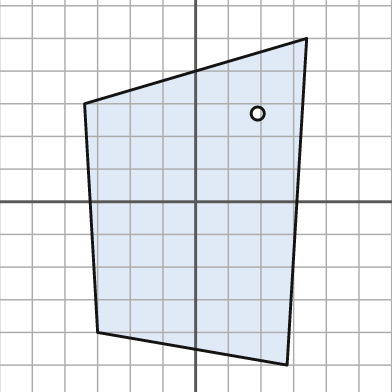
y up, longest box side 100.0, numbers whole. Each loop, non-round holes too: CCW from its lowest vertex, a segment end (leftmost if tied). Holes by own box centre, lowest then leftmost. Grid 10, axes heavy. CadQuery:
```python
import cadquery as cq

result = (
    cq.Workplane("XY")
    .moveTo(28.0, -50.0)
    .lineTo(34.0, 50.0)
    .lineTo(-34.0, 30.0)
    .lineTo(-30.0, -40.0)
    .close()
    .moveTo(19.0, 27.0)
    .circle(2.0)
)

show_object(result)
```